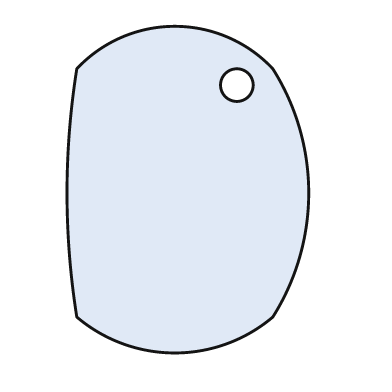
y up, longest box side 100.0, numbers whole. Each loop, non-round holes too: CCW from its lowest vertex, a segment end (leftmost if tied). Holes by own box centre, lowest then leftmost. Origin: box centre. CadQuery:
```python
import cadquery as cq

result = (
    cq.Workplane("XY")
    .moveTo(-34.0, -39.0)
    .threePointArc((-4.0, -50.0), (26.0, -39.0))
    .threePointArc((37.0, -1.0), (26.0, 37.0))
    .threePointArc((-4.0, 50.0), (-34.0, 37.0))
    .threePointArc((-37.0, -1.0), (-34.0, -39.0))
    .close()
    .moveTo(15.0, 32.0)
    .circle(5.0)
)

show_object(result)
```